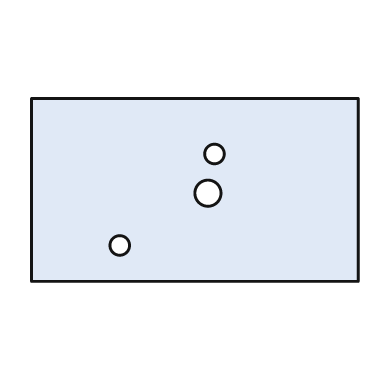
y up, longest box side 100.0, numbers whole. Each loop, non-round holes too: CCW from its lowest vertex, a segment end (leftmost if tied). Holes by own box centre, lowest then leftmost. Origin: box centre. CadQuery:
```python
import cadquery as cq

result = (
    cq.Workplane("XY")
    .moveTo(-50.0, -28.0)
    .lineTo(50.0, -28.0)
    .lineTo(50.0, 28.0)
    .lineTo(-50.0, 28.0)
    .close()
    .moveTo(-23.0, -17.0)
    .circle(3.0)
    .moveTo(4.0, -1.0)
    .circle(4.0)
    .moveTo(6.0, 11.0)
    .circle(3.0)
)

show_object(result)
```